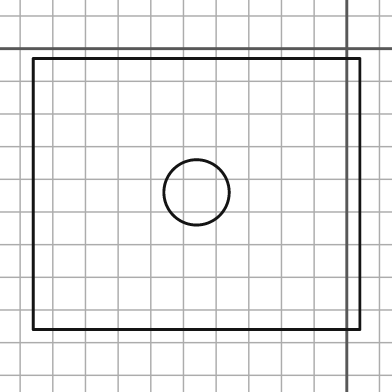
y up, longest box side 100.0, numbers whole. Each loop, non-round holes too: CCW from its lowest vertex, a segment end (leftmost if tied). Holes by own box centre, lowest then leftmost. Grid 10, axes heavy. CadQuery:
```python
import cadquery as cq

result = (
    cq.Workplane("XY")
    .moveTo(-96.0, -86.0)
    .lineTo(4.0, -86.0)
    .lineTo(4.0, -3.0)
    .lineTo(-96.0, -3.0)
    .close()
    .moveTo(-46.0, -44.0)
    .circle(10.0)
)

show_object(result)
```